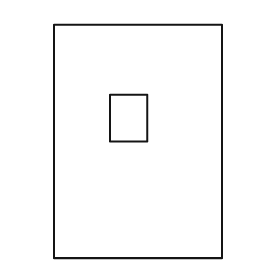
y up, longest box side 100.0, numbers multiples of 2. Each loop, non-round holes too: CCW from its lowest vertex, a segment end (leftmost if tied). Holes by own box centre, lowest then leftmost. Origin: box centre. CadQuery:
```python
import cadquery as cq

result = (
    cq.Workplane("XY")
    .moveTo(-36.0, -50.0)
    .lineTo(36.0, -50.0)
    .lineTo(36.0, 50.0)
    .lineTo(-36.0, 50.0)
    .close()
    .moveTo(-12.0, 0.0)
    .lineTo(4.0, 0.0)
    .lineTo(4.0, 20.0)
    .lineTo(-12.0, 20.0)
    .close()
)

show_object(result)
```